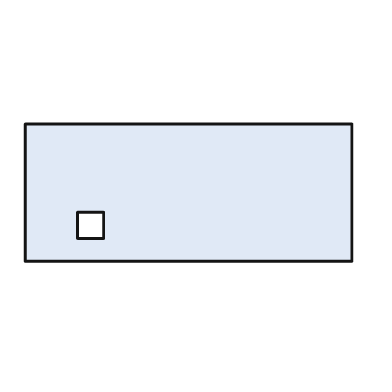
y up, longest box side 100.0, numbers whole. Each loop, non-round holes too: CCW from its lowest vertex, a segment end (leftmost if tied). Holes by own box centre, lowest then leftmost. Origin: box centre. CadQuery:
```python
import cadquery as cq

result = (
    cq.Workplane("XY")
    .moveTo(-50.0, -21.0)
    .lineTo(50.0, -21.0)
    .lineTo(50.0, 21.0)
    .lineTo(-50.0, 21.0)
    .close()
    .moveTo(-34.0, -14.0)
    .lineTo(-26.0, -14.0)
    .lineTo(-26.0, -6.0)
    .lineTo(-34.0, -6.0)
    .close()
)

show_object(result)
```